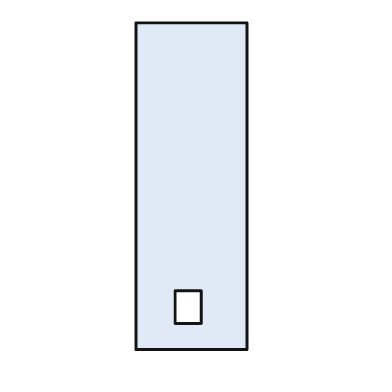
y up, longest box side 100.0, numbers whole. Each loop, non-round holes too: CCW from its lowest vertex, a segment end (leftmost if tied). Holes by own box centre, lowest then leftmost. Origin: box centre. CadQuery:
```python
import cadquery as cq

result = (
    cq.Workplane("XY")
    .moveTo(-17.0, -50.0)
    .lineTo(17.0, -50.0)
    .lineTo(17.0, 50.0)
    .lineTo(-17.0, 50.0)
    .close()
    .moveTo(-5.0, -42.0)
    .lineTo(3.0, -42.0)
    .lineTo(3.0, -32.0)
    .lineTo(-5.0, -32.0)
    .close()
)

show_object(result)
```